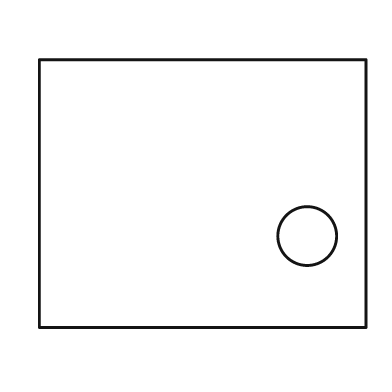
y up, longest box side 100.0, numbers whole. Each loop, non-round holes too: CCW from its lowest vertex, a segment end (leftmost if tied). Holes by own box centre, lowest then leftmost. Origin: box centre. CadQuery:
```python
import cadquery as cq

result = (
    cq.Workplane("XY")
    .moveTo(-50.0, -41.0)
    .lineTo(50.0, -41.0)
    .lineTo(50.0, 41.0)
    .lineTo(-50.0, 41.0)
    .close()
    .moveTo(32.0, -13.0)
    .circle(9.0)
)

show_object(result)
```